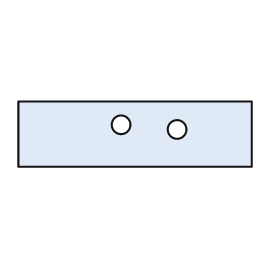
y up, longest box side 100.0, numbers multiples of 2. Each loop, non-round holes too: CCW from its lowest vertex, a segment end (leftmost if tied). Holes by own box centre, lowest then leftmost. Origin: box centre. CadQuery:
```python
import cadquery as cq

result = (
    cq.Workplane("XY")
    .moveTo(-50.0, -14.0)
    .lineTo(50.0, -14.0)
    .lineTo(50.0, 14.0)
    .lineTo(-50.0, 14.0)
    .close()
    .moveTo(18.0, 2.0)
    .circle(4.0)
    .moveTo(-6.0, 4.0)
    .circle(4.0)
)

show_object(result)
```